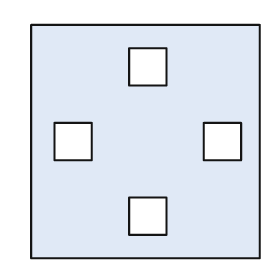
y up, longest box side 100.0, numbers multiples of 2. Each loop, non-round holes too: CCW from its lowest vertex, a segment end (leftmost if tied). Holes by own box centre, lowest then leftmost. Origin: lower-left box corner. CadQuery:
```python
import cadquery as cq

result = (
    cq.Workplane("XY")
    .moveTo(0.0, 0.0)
    .lineTo(98.0, 0.0)
    .lineTo(98.0, 100.0)
    .lineTo(0.0, 100.0)
    .close()
    .moveTo(42.0, 10.0)
    .lineTo(58.0, 10.0)
    .lineTo(58.0, 26.0)
    .lineTo(42.0, 26.0)
    .close()
    .moveTo(10.0, 42.0)
    .lineTo(26.0, 42.0)
    .lineTo(26.0, 58.0)
    .lineTo(10.0, 58.0)
    .close()
    .moveTo(74.0, 42.0)
    .lineTo(90.0, 42.0)
    .lineTo(90.0, 58.0)
    .lineTo(74.0, 58.0)
    .close()
    .moveTo(42.0, 74.0)
    .lineTo(58.0, 74.0)
    .lineTo(58.0, 90.0)
    .lineTo(42.0, 90.0)
    .close()
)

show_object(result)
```